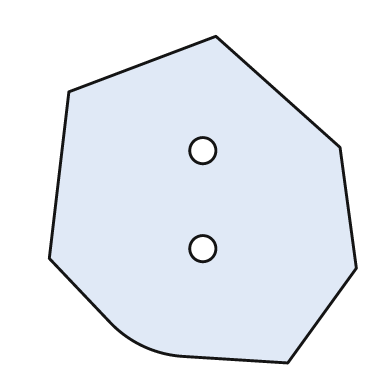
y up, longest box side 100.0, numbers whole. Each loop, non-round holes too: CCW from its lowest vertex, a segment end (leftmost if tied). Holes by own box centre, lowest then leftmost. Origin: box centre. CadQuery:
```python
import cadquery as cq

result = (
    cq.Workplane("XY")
    .moveTo(26.0, -50.0)
    .lineTo(47.0, -21.0)
    .lineTo(42.0, 16.0)
    .lineTo(4.0, 50.0)
    .lineTo(-41.0, 33.0)
    .lineTo(-47.0, -18.0)
    .lineTo(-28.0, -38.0)
    .threePointArc((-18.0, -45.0), (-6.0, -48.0))
    .close()
    .moveTo(0.0, -15.0)
    .circle(4.0)
    .moveTo(0.0, 15.0)
    .circle(4.0)
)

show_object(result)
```